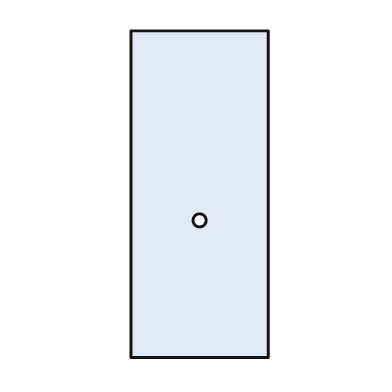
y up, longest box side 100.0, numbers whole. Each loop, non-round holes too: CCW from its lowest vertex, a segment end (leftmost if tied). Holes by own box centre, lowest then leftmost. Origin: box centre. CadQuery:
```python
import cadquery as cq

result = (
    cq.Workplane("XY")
    .moveTo(-21.0, -50.0)
    .lineTo(21.0, -50.0)
    .lineTo(21.0, 50.0)
    .lineTo(-21.0, 50.0)
    .close()
    .moveTo(0.0, -8.0)
    .circle(2.0)
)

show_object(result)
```